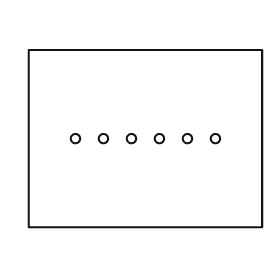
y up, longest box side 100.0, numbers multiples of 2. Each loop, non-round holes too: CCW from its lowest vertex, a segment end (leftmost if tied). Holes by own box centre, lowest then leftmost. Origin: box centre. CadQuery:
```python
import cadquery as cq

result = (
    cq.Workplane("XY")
    .moveTo(-50.0, -38.0)
    .lineTo(50.0, -38.0)
    .lineTo(50.0, 38.0)
    .lineTo(-50.0, 38.0)
    .close()
    .moveTo(-30.0, 0.0)
    .circle(2.0)
    .moveTo(-18.0, 0.0)
    .circle(2.0)
    .moveTo(-6.0, 0.0)
    .circle(2.0)
    .moveTo(6.0, 0.0)
    .circle(2.0)
    .moveTo(18.0, 0.0)
    .circle(2.0)
    .moveTo(30.0, 0.0)
    .circle(2.0)
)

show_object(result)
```